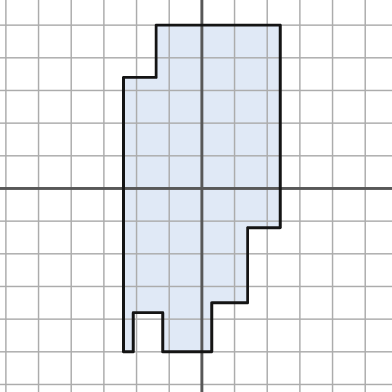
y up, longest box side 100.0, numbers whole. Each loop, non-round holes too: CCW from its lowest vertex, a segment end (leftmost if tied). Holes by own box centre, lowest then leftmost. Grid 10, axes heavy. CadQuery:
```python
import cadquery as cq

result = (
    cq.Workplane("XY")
    .moveTo(-24.0, -50.0)
    .lineTo(-21.0, -50.0)
    .lineTo(-21.0, -38.0)
    .lineTo(-12.0, -38.0)
    .lineTo(-12.0, -50.0)
    .lineTo(3.0, -50.0)
    .lineTo(3.0, -35.0)
    .lineTo(14.0, -35.0)
    .lineTo(14.0, -12.0)
    .lineTo(24.0, -12.0)
    .lineTo(24.0, 50.0)
    .lineTo(-14.0, 50.0)
    .lineTo(-14.0, 34.0)
    .lineTo(-24.0, 34.0)
    .close()
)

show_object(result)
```